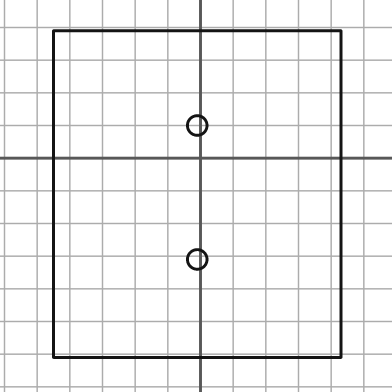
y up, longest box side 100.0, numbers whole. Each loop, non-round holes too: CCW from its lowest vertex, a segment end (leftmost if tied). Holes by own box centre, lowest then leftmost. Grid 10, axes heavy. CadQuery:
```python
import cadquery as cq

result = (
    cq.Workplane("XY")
    .moveTo(-45.0, -61.0)
    .lineTo(43.0, -61.0)
    .lineTo(43.0, 39.0)
    .lineTo(-45.0, 39.0)
    .close()
    .moveTo(-1.0, -31.0)
    .circle(3.0)
    .moveTo(-1.0, 10.0)
    .circle(3.0)
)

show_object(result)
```